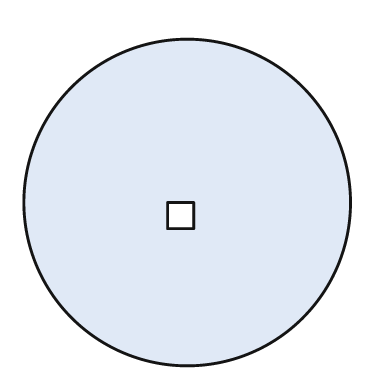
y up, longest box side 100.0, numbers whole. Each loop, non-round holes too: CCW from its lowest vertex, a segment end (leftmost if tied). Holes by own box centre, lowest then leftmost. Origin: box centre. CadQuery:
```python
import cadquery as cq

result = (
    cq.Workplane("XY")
    .moveTo(0.0, 0.0)
    .circle(50.0)
    .moveTo(-6.0, -8.0)
    .lineTo(2.0, -8.0)
    .lineTo(2.0, 0.0)
    .lineTo(-6.0, 0.0)
    .close()
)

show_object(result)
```